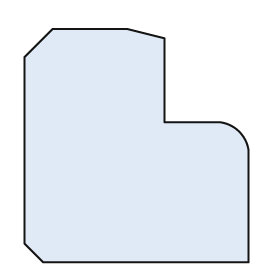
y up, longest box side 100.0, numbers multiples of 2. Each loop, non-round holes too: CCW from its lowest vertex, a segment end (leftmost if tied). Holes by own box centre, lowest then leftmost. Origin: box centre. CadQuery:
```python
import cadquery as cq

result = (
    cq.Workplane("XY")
    .moveTo(-40.0, -50.0)
    .lineTo(48.0, -50.0)
    .lineTo(48.0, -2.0)
    .threePointArc((44.0, 6.0), (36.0, 10.0))
    .lineTo(12.0, 10.0)
    .lineTo(12.0, 46.0)
    .lineTo(-4.0, 50.0)
    .lineTo(-36.0, 50.0)
    .lineTo(-48.0, 38.0)
    .lineTo(-48.0, -42.0)
    .close()
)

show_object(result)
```